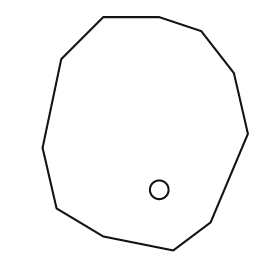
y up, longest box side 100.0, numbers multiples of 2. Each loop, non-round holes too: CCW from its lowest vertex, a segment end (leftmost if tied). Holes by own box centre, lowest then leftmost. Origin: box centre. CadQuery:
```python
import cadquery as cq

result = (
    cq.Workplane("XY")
    .moveTo(12.0, -50.0)
    .lineTo(28.0, -38.0)
    .lineTo(44.0, 0.0)
    .lineTo(38.0, 26.0)
    .lineTo(24.0, 44.0)
    .lineTo(6.0, 50.0)
    .lineTo(-18.0, 50.0)
    .lineTo(-36.0, 32.0)
    .lineTo(-44.0, -6.0)
    .lineTo(-38.0, -32.0)
    .lineTo(-18.0, -44.0)
    .close()
    .moveTo(6.0, -24.0)
    .circle(4.0)
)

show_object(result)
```